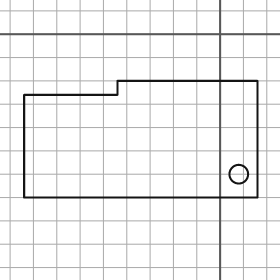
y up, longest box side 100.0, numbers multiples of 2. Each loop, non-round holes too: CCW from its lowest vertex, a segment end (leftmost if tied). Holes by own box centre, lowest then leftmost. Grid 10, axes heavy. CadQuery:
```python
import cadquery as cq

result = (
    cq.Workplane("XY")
    .moveTo(-84.0, -70.0)
    .lineTo(16.0, -70.0)
    .lineTo(16.0, -20.0)
    .lineTo(-44.0, -20.0)
    .lineTo(-44.0, -26.0)
    .lineTo(-84.0, -26.0)
    .close()
    .moveTo(8.0, -60.0)
    .circle(4.0)
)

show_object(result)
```